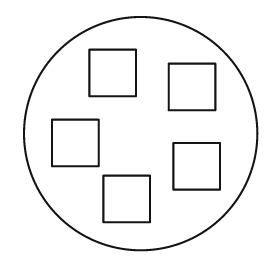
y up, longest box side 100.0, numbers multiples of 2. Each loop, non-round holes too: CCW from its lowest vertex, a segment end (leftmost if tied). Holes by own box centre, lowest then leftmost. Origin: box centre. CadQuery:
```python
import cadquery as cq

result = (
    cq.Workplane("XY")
    .moveTo(0.0, 0.0)
    .circle(50.0)
    .moveTo(-16.0, -38.0)
    .lineTo(4.0, -38.0)
    .lineTo(4.0, -18.0)
    .lineTo(-16.0, -18.0)
    .close()
    .moveTo(14.0, -24.0)
    .lineTo(34.0, -24.0)
    .lineTo(34.0, -4.0)
    .lineTo(14.0, -4.0)
    .close()
    .moveTo(-38.0, -14.0)
    .lineTo(-18.0, -14.0)
    .lineTo(-18.0, 6.0)
    .lineTo(-38.0, 6.0)
    .close()
    .moveTo(12.0, 10.0)
    .lineTo(32.0, 10.0)
    .lineTo(32.0, 30.0)
    .lineTo(12.0, 30.0)
    .close()
    .moveTo(-22.0, 16.0)
    .lineTo(-2.0, 16.0)
    .lineTo(-2.0, 36.0)
    .lineTo(-22.0, 36.0)
    .close()
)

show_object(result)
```